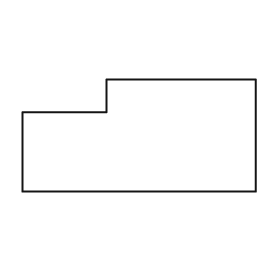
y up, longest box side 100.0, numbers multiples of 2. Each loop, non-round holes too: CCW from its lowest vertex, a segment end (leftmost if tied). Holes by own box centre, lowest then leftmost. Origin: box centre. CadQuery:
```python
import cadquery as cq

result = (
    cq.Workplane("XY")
    .moveTo(-50.0, -24.0)
    .lineTo(50.0, -24.0)
    .lineTo(50.0, 24.0)
    .lineTo(-14.0, 24.0)
    .lineTo(-14.0, 10.0)
    .lineTo(-50.0, 10.0)
    .close()
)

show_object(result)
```